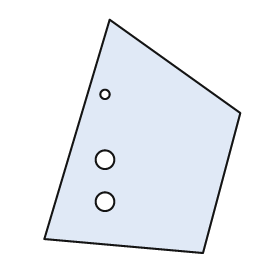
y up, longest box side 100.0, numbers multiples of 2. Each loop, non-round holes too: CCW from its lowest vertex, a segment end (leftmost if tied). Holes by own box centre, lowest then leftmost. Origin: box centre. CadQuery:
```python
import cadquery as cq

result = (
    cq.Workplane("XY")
    .moveTo(26.0, -50.0)
    .lineTo(42.0, 10.0)
    .lineTo(-14.0, 50.0)
    .lineTo(-42.0, -44.0)
    .close()
    .moveTo(-16.0, -28.0)
    .circle(4.0)
    .moveTo(-16.0, -10.0)
    .circle(4.0)
    .moveTo(-16.0, 18.0)
    .circle(2.0)
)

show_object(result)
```